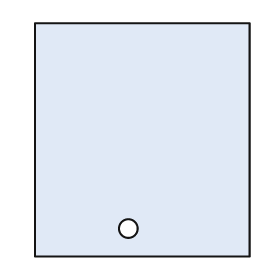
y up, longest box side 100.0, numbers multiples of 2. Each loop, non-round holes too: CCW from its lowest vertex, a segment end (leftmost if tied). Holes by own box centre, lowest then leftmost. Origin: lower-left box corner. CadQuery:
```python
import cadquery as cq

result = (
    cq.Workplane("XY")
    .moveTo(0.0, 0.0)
    .lineTo(92.0, 0.0)
    .lineTo(92.0, 100.0)
    .lineTo(0.0, 100.0)
    .close()
    .moveTo(40.0, 12.0)
    .circle(4.0)
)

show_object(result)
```